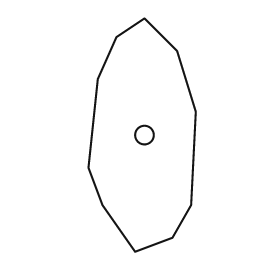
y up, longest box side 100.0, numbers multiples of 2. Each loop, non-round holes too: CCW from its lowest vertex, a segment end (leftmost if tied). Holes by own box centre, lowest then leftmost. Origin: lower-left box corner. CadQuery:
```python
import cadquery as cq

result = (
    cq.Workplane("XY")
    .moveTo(20.0, 0.0)
    .lineTo(36.0, 6.0)
    .lineTo(44.0, 20.0)
    .lineTo(46.0, 60.0)
    .lineTo(38.0, 86.0)
    .lineTo(24.0, 100.0)
    .lineTo(12.0, 92.0)
    .lineTo(4.0, 74.0)
    .lineTo(0.0, 36.0)
    .lineTo(6.0, 20.0)
    .close()
    .moveTo(24.0, 50.0)
    .circle(4.0)
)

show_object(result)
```